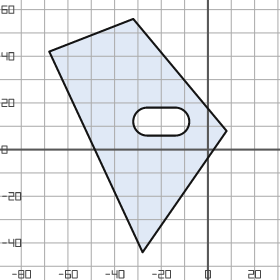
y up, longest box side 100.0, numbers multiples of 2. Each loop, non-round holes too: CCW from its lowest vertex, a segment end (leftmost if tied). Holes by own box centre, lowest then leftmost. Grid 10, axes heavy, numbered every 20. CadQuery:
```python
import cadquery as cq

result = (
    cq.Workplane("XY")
    .moveTo(-28.0, -44.0)
    .lineTo(8.0, 8.0)
    .lineTo(-32.0, 56.0)
    .lineTo(-68.0, 42.0)
    .close()
    .moveTo(-26.0, 6.0)
    .lineTo(-14.0, 6.0)
    .threePointArc((-8.0, 12.0), (-14.0, 18.0))
    .lineTo(-26.0, 18.0)
    .threePointArc((-32.0, 12.0), (-26.0, 6.0))
    .close()
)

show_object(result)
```